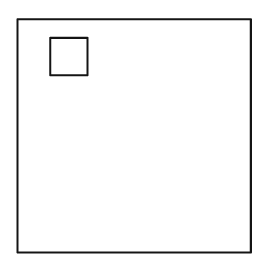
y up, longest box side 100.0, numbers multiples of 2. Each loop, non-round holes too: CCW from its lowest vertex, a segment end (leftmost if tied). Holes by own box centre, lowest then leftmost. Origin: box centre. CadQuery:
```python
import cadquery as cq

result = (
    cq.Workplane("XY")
    .moveTo(-50.0, -50.0)
    .lineTo(50.0, -50.0)
    .lineTo(50.0, 50.0)
    .lineTo(-50.0, 50.0)
    .close()
    .moveTo(-36.0, 26.0)
    .lineTo(-20.0, 26.0)
    .lineTo(-20.0, 42.0)
    .lineTo(-36.0, 42.0)
    .close()
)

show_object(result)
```